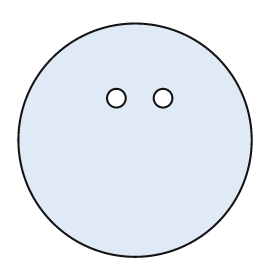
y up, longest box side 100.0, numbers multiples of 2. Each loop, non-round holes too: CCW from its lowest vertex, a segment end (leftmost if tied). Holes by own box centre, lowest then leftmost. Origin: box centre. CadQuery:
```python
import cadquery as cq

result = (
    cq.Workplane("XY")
    .moveTo(0.0, 0.0)
    .circle(50.0)
    .moveTo(-8.0, 18.0)
    .circle(4.0)
    .moveTo(12.0, 18.0)
    .circle(4.0)
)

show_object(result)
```